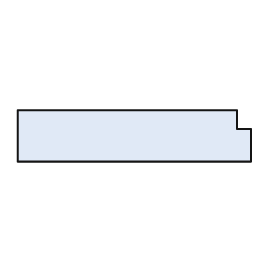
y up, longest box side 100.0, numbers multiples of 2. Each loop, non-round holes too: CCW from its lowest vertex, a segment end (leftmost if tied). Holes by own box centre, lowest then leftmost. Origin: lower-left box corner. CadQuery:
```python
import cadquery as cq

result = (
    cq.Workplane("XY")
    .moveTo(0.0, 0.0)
    .lineTo(100.0, 0.0)
    .lineTo(100.0, 14.0)
    .lineTo(94.0, 14.0)
    .lineTo(94.0, 22.0)
    .lineTo(0.0, 22.0)
    .close()
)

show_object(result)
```